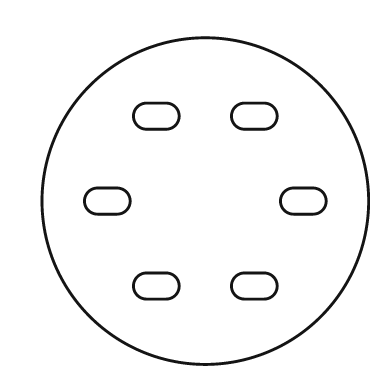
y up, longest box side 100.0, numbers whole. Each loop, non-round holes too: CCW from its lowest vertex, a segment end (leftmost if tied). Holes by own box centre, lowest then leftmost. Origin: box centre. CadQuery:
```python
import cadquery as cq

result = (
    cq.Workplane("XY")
    .moveTo(0.0, 0.0)
    .circle(50.0)
    .moveTo(-18.0, -30.0)
    .lineTo(-12.0, -30.0)
    .threePointArc((-8.0, -26.0), (-12.0, -22.0))
    .lineTo(-18.0, -22.0)
    .threePointArc((-22.0, -26.0), (-18.0, -30.0))
    .close()
    .moveTo(12.0, -30.0)
    .lineTo(18.0, -30.0)
    .threePointArc((22.0, -26.0), (18.0, -22.0))
    .lineTo(12.0, -22.0)
    .threePointArc((8.0, -26.0), (12.0, -30.0))
    .close()
    .moveTo(-33.0, -4.0)
    .lineTo(-27.0, -4.0)
    .threePointArc((-23.0, 0.0), (-27.0, 4.0))
    .lineTo(-33.0, 4.0)
    .threePointArc((-37.0, 0.0), (-33.0, -4.0))
    .close()
    .moveTo(27.0, -4.0)
    .lineTo(33.0, -4.0)
    .threePointArc((37.0, 0.0), (33.0, 4.0))
    .lineTo(27.0, 4.0)
    .threePointArc((23.0, 0.0), (27.0, -4.0))
    .close()
    .moveTo(-18.0, 22.0)
    .lineTo(-12.0, 22.0)
    .threePointArc((-8.0, 26.0), (-12.0, 30.0))
    .lineTo(-18.0, 30.0)
    .threePointArc((-22.0, 26.0), (-18.0, 22.0))
    .close()
    .moveTo(12.0, 22.0)
    .lineTo(18.0, 22.0)
    .threePointArc((22.0, 26.0), (18.0, 30.0))
    .lineTo(12.0, 30.0)
    .threePointArc((8.0, 26.0), (12.0, 22.0))
    .close()
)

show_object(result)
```